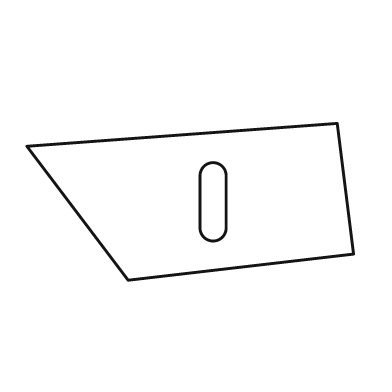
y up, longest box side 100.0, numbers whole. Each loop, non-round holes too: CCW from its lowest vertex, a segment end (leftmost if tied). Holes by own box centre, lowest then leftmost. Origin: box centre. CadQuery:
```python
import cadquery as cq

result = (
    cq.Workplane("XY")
    .moveTo(-19.0, -24.0)
    .lineTo(50.0, -16.0)
    .lineTo(45.0, 24.0)
    .lineTo(-50.0, 17.0)
    .close()
    .moveTo(3.0, -8.0)
    .threePointArc((7.0, -12.0), (11.0, -8.0))
    .lineTo(11.0, 8.0)
    .threePointArc((7.0, 12.0), (3.0, 8.0))
    .close()
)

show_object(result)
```